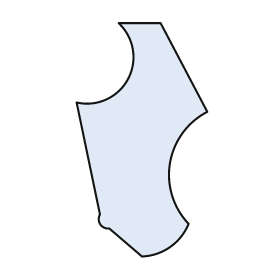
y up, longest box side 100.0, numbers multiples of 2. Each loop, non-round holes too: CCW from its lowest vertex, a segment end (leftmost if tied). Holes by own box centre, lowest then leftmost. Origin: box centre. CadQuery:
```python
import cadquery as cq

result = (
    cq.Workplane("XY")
    .moveTo(0.0, -50.0)
    .threePointArc((12.0, -46.0), (20.0, -36.0))
    .threePointArc((12.0, -10.0), (28.0, 12.0))
    .lineTo(8.0, 50.0)
    .lineTo(-10.0, 50.0)
    .threePointArc((-6.0, 26.0), (-28.0, 16.0))
    .lineTo(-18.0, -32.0)
    .threePointArc((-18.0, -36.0), (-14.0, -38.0))
    .close()
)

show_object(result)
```